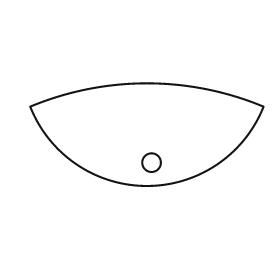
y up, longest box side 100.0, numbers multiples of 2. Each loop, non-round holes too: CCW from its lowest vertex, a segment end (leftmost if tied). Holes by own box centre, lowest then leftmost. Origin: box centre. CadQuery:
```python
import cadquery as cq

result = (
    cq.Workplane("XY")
    .moveTo(-50.0, 12.0)
    .threePointArc((0.0, -22.0), (50.0, 12.0))
    .threePointArc((0.0, 22.0), (-50.0, 12.0))
    .close()
    .moveTo(2.0, -12.0)
    .circle(4.0)
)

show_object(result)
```